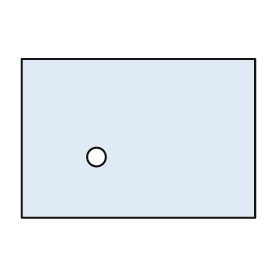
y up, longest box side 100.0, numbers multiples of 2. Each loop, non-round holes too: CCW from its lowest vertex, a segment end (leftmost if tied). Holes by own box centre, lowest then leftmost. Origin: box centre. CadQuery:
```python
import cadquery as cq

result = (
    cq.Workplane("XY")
    .moveTo(-50.0, -34.0)
    .lineTo(50.0, -34.0)
    .lineTo(50.0, 34.0)
    .lineTo(-50.0, 34.0)
    .close()
    .moveTo(-18.0, -8.0)
    .circle(4.0)
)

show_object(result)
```